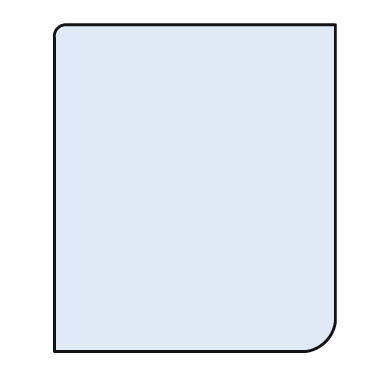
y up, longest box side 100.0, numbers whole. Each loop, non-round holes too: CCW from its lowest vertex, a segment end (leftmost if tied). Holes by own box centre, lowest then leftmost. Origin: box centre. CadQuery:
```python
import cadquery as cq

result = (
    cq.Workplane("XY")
    .moveTo(-43.0, -50.0)
    .lineTo(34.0, -50.0)
    .threePointArc((40.0, -47.0), (43.0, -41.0))
    .lineTo(43.0, 50.0)
    .lineTo(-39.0, 50.0)
    .threePointArc((-42.0, 49.0), (-43.0, 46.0))
    .close()
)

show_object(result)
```